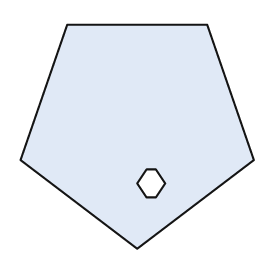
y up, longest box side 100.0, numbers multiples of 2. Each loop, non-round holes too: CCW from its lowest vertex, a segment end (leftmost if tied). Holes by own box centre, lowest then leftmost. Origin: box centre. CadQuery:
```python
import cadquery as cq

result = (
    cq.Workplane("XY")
    .moveTo(0.0, -48.0)
    .lineTo(50.0, -10.0)
    .lineTo(30.0, 48.0)
    .lineTo(-30.0, 48.0)
    .lineTo(-50.0, -10.0)
    .close()
    .moveTo(4.0, -26.0)
    .lineTo(8.0, -26.0)
    .lineTo(12.0, -20.0)
    .lineTo(8.0, -14.0)
    .lineTo(4.0, -14.0)
    .lineTo(0.0, -20.0)
    .close()
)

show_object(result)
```